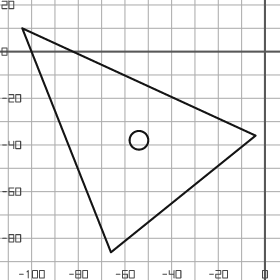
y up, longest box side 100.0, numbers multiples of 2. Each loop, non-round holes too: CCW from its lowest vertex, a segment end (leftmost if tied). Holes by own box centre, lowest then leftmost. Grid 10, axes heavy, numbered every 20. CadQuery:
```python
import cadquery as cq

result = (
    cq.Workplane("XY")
    .moveTo(-66.0, -86.0)
    .lineTo(-4.0, -36.0)
    .lineTo(-104.0, 10.0)
    .close()
    .moveTo(-54.0, -38.0)
    .circle(4.0)
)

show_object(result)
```